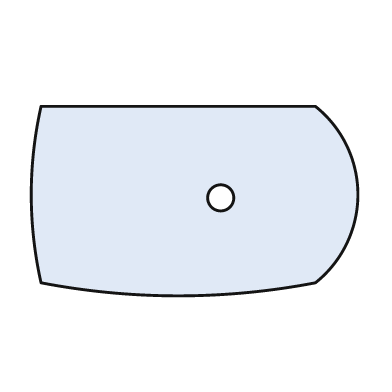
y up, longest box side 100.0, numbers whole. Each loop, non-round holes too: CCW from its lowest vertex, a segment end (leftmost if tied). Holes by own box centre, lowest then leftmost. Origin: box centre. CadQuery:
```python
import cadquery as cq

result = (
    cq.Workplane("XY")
    .moveTo(-47.0, -25.0)
    .threePointArc((-5.0, -29.0), (37.0, -25.0))
    .threePointArc((50.0, 2.0), (37.0, 29.0))
    .lineTo(-47.0, 29.0)
    .threePointArc((-50.0, 2.0), (-47.0, -25.0))
    .close()
    .moveTo(8.0, 1.0)
    .circle(4.0)
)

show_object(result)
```